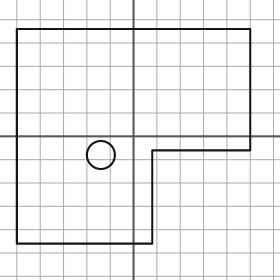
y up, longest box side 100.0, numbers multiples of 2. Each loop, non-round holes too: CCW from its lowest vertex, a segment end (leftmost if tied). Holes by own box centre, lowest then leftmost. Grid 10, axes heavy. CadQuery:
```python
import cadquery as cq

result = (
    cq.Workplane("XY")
    .moveTo(-50.0, -46.0)
    .lineTo(8.0, -46.0)
    .lineTo(8.0, -6.0)
    .lineTo(50.0, -6.0)
    .lineTo(50.0, 46.0)
    .lineTo(-50.0, 46.0)
    .close()
    .moveTo(-14.0, -8.0)
    .circle(6.0)
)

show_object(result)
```